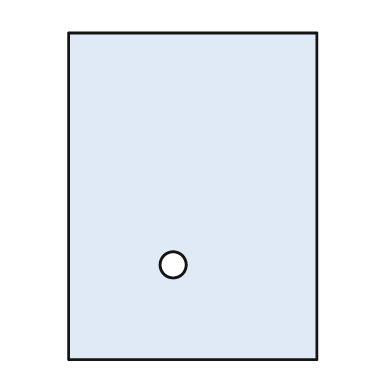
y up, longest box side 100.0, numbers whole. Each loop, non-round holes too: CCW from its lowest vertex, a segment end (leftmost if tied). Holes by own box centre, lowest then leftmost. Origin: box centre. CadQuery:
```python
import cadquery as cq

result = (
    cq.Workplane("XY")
    .moveTo(-38.0, -50.0)
    .lineTo(38.0, -50.0)
    .lineTo(38.0, 50.0)
    .lineTo(-38.0, 50.0)
    .close()
    .moveTo(-6.0, -21.0)
    .circle(4.0)
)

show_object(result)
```